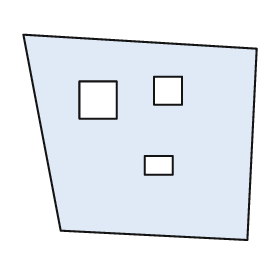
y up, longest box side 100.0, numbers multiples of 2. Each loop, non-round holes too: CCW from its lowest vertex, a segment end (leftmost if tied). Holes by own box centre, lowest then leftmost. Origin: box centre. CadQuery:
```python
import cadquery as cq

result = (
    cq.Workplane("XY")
    .moveTo(46.0, -44.0)
    .lineTo(50.0, 38.0)
    .lineTo(-50.0, 44.0)
    .lineTo(-34.0, -40.0)
    .close()
    .moveTo(2.0, -16.0)
    .lineTo(14.0, -16.0)
    .lineTo(14.0, -8.0)
    .lineTo(2.0, -8.0)
    .close()
    .moveTo(-26.0, 8.0)
    .lineTo(-10.0, 8.0)
    .lineTo(-10.0, 24.0)
    .lineTo(-26.0, 24.0)
    .close()
    .moveTo(6.0, 14.0)
    .lineTo(18.0, 14.0)
    .lineTo(18.0, 26.0)
    .lineTo(6.0, 26.0)
    .close()
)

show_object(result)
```